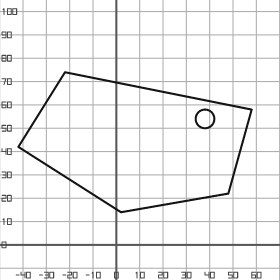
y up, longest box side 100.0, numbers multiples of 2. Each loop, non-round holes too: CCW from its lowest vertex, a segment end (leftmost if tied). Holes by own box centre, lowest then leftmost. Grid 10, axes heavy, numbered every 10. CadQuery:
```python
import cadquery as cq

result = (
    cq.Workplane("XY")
    .moveTo(2.0, 14.0)
    .lineTo(48.0, 22.0)
    .lineTo(58.0, 58.0)
    .lineTo(-22.0, 74.0)
    .lineTo(-42.0, 42.0)
    .close()
    .moveTo(38.0, 54.0)
    .circle(4.0)
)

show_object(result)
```